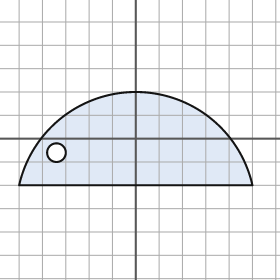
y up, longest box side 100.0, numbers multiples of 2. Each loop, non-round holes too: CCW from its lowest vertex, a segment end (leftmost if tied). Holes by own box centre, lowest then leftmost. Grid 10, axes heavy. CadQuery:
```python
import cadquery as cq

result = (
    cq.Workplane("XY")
    .moveTo(-50.0, -20.0)
    .lineTo(50.0, -20.0)
    .threePointArc((0.0, 20.0), (-50.0, -20.0))
    .close()
    .moveTo(-34.0, -6.0)
    .circle(4.0)
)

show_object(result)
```